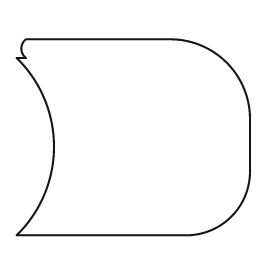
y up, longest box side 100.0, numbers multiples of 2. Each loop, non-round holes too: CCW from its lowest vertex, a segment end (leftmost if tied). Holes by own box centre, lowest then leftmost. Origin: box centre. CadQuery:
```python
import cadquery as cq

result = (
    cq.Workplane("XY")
    .moveTo(-50.0, -42.0)
    .lineTo(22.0, -42.0)
    .threePointArc((42.0, -34.0), (50.0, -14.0))
    .lineTo(50.0, 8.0)
    .threePointArc((40.0, 32.0), (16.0, 42.0))
    .lineTo(-46.0, 42.0)
    .threePointArc((-48.0, 38.0), (-46.0, 34.0))
    .lineTo(-50.0, 34.0)
    .threePointArc((-34.0, -4.0), (-50.0, -42.0))
    .close()
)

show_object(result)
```